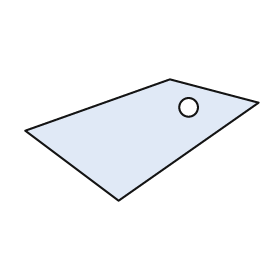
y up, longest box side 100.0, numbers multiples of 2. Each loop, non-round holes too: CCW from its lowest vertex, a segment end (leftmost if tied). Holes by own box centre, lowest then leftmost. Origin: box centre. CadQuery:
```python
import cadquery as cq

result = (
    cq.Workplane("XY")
    .moveTo(-10.0, -26.0)
    .lineTo(50.0, 16.0)
    .lineTo(12.0, 26.0)
    .lineTo(-50.0, 4.0)
    .close()
    .moveTo(20.0, 14.0)
    .circle(4.0)
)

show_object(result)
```